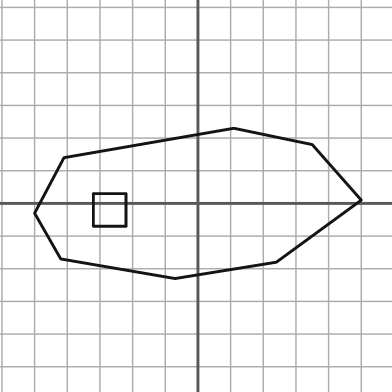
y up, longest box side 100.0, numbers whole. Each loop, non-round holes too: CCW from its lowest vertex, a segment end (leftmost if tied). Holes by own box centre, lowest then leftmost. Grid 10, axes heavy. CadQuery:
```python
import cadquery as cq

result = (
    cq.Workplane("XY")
    .moveTo(-7.0, -23.0)
    .lineTo(24.0, -18.0)
    .lineTo(50.0, 1.0)
    .lineTo(35.0, 18.0)
    .lineTo(11.0, 23.0)
    .lineTo(-41.0, 14.0)
    .lineTo(-50.0, -3.0)
    .lineTo(-42.0, -17.0)
    .close()
    .moveTo(-32.0, -7.0)
    .lineTo(-22.0, -7.0)
    .lineTo(-22.0, 3.0)
    .lineTo(-32.0, 3.0)
    .close()
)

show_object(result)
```